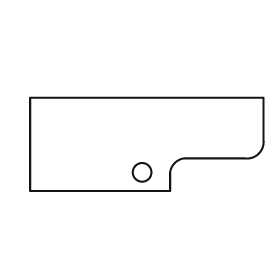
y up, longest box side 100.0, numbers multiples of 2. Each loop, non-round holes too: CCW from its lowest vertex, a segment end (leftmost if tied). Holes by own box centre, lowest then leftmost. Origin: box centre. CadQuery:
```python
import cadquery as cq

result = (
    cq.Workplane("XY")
    .moveTo(-50.0, -20.0)
    .lineTo(10.0, -20.0)
    .lineTo(10.0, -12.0)
    .threePointArc((12.0, -8.0), (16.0, -6.0))
    .lineTo(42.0, -6.0)
    .threePointArc((48.0, -4.0), (50.0, 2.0))
    .lineTo(50.0, 20.0)
    .lineTo(-50.0, 20.0)
    .close()
    .moveTo(-2.0, -12.0)
    .circle(4.0)
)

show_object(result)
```